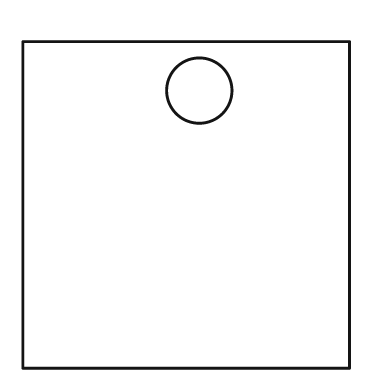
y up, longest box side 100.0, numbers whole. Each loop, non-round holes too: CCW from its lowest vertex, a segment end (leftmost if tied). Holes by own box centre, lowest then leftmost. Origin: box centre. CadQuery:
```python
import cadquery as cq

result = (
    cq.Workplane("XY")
    .moveTo(-50.0, -50.0)
    .lineTo(50.0, -50.0)
    .lineTo(50.0, 50.0)
    .lineTo(-50.0, 50.0)
    .close()
    .moveTo(4.0, 35.0)
    .circle(10.0)
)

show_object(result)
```